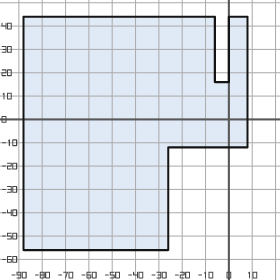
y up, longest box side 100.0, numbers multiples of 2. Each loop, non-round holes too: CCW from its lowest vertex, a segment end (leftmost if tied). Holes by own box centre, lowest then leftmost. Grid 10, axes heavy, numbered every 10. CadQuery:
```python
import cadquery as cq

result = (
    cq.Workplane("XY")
    .moveTo(-88.0, -56.0)
    .lineTo(-26.0, -56.0)
    .lineTo(-26.0, -12.0)
    .lineTo(8.0, -12.0)
    .lineTo(8.0, 44.0)
    .lineTo(0.0, 44.0)
    .lineTo(0.0, 16.0)
    .lineTo(-6.0, 16.0)
    .lineTo(-6.0, 44.0)
    .lineTo(-88.0, 44.0)
    .close()
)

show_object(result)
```